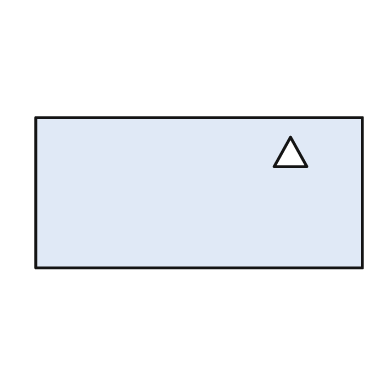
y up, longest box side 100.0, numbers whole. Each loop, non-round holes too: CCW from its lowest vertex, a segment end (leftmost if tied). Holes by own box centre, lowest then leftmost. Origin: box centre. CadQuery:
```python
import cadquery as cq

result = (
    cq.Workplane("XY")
    .moveTo(-50.0, -23.0)
    .lineTo(50.0, -23.0)
    .lineTo(50.0, 23.0)
    .lineTo(-50.0, 23.0)
    .close()
    .moveTo(23.0, 8.0)
    .lineTo(33.0, 8.0)
    .lineTo(28.0, 17.0)
    .close()
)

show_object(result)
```